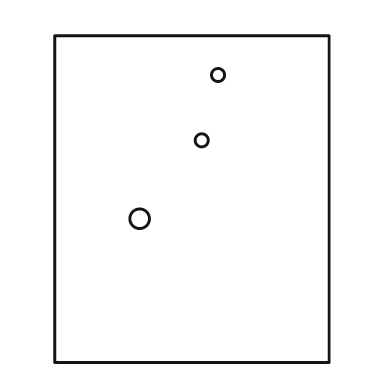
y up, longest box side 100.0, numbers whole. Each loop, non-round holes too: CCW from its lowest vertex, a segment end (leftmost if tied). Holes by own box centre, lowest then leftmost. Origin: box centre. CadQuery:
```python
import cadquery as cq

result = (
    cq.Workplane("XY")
    .moveTo(-42.0, -50.0)
    .lineTo(42.0, -50.0)
    .lineTo(42.0, 50.0)
    .lineTo(-42.0, 50.0)
    .close()
    .moveTo(-16.0, -6.0)
    .circle(3.0)
    .moveTo(3.0, 18.0)
    .circle(2.0)
    .moveTo(8.0, 38.0)
    .circle(2.0)
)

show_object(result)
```